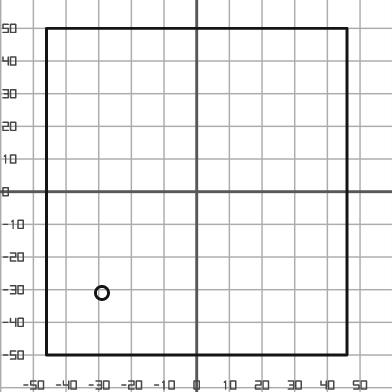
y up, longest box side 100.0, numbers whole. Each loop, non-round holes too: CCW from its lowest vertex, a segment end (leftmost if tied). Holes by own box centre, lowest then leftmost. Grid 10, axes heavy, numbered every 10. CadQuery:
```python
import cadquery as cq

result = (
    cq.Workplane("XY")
    .moveTo(-46.0, -50.0)
    .lineTo(46.0, -50.0)
    .lineTo(46.0, 50.0)
    .lineTo(-46.0, 50.0)
    .close()
    .moveTo(-29.0, -31.0)
    .circle(2.0)
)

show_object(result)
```